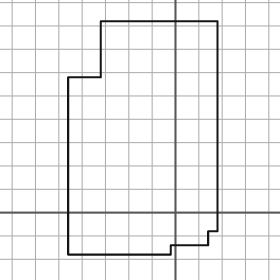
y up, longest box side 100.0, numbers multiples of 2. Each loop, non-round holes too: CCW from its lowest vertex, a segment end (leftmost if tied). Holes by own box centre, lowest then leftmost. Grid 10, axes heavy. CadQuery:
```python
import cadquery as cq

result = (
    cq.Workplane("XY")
    .moveTo(-46.0, -18.0)
    .lineTo(-2.0, -18.0)
    .lineTo(-2.0, -14.0)
    .lineTo(14.0, -14.0)
    .lineTo(14.0, -8.0)
    .lineTo(18.0, -8.0)
    .lineTo(18.0, 82.0)
    .lineTo(-32.0, 82.0)
    .lineTo(-32.0, 58.0)
    .lineTo(-46.0, 58.0)
    .close()
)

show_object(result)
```